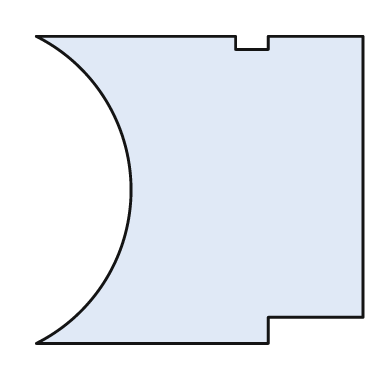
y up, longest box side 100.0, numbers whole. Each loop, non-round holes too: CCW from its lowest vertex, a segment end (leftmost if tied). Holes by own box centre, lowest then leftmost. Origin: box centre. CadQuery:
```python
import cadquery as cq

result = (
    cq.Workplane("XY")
    .moveTo(-50.0, -47.0)
    .lineTo(21.0, -47.0)
    .lineTo(21.0, -39.0)
    .lineTo(50.0, -39.0)
    .lineTo(50.0, 47.0)
    .lineTo(21.0, 47.0)
    .lineTo(21.0, 43.0)
    .lineTo(11.0, 43.0)
    .lineTo(11.0, 47.0)
    .lineTo(-50.0, 47.0)
    .threePointArc((-21.0, 0.0), (-50.0, -47.0))
    .close()
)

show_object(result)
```